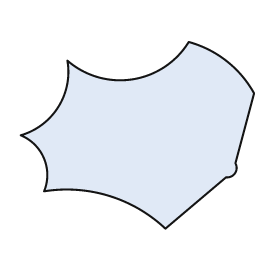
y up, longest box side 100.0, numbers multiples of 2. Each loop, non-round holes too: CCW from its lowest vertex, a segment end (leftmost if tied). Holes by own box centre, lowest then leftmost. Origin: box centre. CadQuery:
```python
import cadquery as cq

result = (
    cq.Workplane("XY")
    .moveTo(12.0, -40.0)
    .lineTo(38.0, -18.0)
    .threePointArc((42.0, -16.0), (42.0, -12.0))
    .lineTo(50.0, 18.0)
    .threePointArc((38.0, 32.0), (22.0, 40.0))
    .threePointArc((-2.0, 24.0), (-30.0, 32.0))
    .threePointArc((-34.0, 12.0), (-50.0, 0.0))
    .threePointArc((-40.0, -10.0), (-40.0, -24.0))
    .threePointArc((-12.0, -26.0), (12.0, -40.0))
    .close()
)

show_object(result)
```